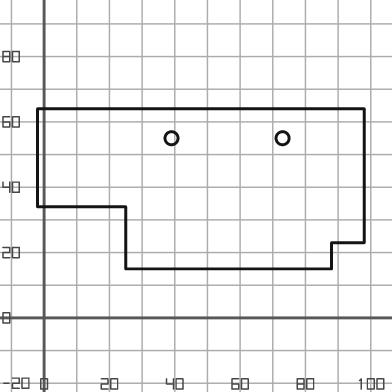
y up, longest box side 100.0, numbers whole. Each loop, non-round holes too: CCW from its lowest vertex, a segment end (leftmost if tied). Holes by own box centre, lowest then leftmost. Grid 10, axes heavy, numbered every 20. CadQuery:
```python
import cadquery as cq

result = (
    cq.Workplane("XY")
    .moveTo(25.0, 15.0)
    .lineTo(88.0, 15.0)
    .lineTo(88.0, 23.0)
    .lineTo(98.0, 23.0)
    .lineTo(98.0, 64.0)
    .lineTo(-2.0, 64.0)
    .lineTo(-2.0, 34.0)
    .lineTo(25.0, 34.0)
    .close()
    .moveTo(39.0, 55.0)
    .circle(2.0)
    .moveTo(73.0, 55.0)
    .circle(2.0)
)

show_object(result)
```